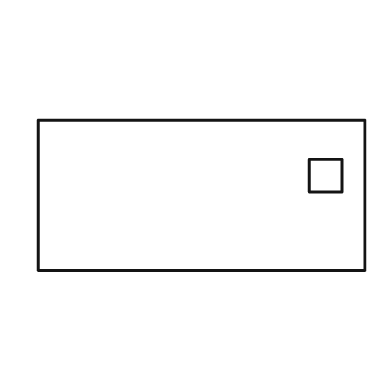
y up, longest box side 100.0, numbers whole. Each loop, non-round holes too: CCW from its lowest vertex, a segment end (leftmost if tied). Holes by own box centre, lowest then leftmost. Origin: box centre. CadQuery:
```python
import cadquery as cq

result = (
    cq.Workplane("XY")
    .moveTo(-50.0, -23.0)
    .lineTo(50.0, -23.0)
    .lineTo(50.0, 23.0)
    .lineTo(-50.0, 23.0)
    .close()
    .moveTo(33.0, 1.0)
    .lineTo(43.0, 1.0)
    .lineTo(43.0, 11.0)
    .lineTo(33.0, 11.0)
    .close()
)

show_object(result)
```